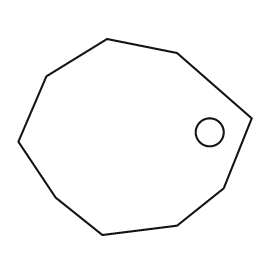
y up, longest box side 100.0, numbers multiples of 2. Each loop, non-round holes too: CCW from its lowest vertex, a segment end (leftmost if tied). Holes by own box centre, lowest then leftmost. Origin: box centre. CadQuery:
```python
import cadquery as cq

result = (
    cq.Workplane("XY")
    .moveTo(-14.0, -42.0)
    .lineTo(18.0, -38.0)
    .lineTo(38.0, -22.0)
    .lineTo(50.0, 8.0)
    .lineTo(18.0, 36.0)
    .lineTo(-12.0, 42.0)
    .lineTo(-38.0, 26.0)
    .lineTo(-50.0, -2.0)
    .lineTo(-34.0, -26.0)
    .close()
    .moveTo(32.0, 2.0)
    .circle(6.0)
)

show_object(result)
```